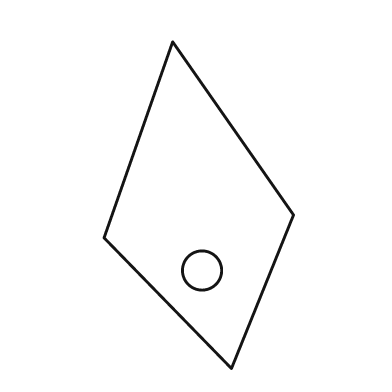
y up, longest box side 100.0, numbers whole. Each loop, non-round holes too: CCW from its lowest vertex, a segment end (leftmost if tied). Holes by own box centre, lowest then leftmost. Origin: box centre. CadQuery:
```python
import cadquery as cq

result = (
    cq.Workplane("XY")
    .moveTo(10.0, -50.0)
    .lineTo(29.0, -3.0)
    .lineTo(-8.0, 50.0)
    .lineTo(-29.0, -10.0)
    .close()
    .moveTo(1.0, -20.0)
    .circle(6.0)
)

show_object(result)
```